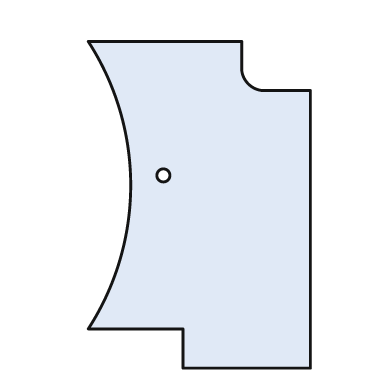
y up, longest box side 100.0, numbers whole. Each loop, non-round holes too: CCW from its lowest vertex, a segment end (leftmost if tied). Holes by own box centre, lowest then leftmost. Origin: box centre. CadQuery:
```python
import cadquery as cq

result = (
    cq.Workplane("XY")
    .moveTo(-5.0, -50.0)
    .lineTo(34.0, -50.0)
    .lineTo(34.0, 35.0)
    .lineTo(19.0, 35.0)
    .threePointArc((15.0, 37.0), (13.0, 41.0))
    .lineTo(13.0, 50.0)
    .lineTo(-34.0, 50.0)
    .threePointArc((-21.0, 6.0), (-34.0, -38.0))
    .lineTo(-5.0, -38.0)
    .close()
    .moveTo(-11.0, 9.0)
    .circle(2.0)
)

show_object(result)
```